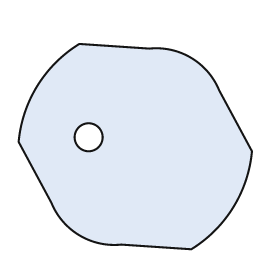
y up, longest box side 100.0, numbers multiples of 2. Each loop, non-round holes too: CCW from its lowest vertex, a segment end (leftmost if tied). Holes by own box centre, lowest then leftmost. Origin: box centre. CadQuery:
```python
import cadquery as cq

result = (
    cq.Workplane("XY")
    .moveTo(24.0, -44.0)
    .threePointArc((42.0, -26.0), (50.0, -2.0))
    .lineTo(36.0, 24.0)
    .threePointArc((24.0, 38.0), (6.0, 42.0))
    .lineTo(-24.0, 44.0)
    .threePointArc((-42.0, 26.0), (-50.0, 2.0))
    .lineTo(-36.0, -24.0)
    .threePointArc((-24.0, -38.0), (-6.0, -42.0))
    .close()
    .moveTo(-20.0, 4.0)
    .circle(6.0)
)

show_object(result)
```